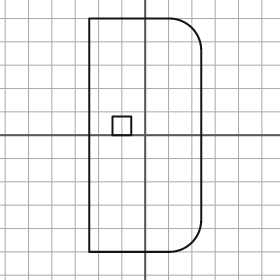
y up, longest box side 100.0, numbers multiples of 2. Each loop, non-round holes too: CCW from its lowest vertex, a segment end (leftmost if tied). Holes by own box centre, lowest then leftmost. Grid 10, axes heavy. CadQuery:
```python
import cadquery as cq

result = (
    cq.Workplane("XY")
    .moveTo(-24.0, -50.0)
    .lineTo(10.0, -50.0)
    .threePointArc((20.0, -46.0), (24.0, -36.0))
    .lineTo(24.0, 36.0)
    .threePointArc((20.0, 46.0), (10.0, 50.0))
    .lineTo(-24.0, 50.0)
    .close()
    .moveTo(-14.0, 0.0)
    .lineTo(-6.0, 0.0)
    .lineTo(-6.0, 8.0)
    .lineTo(-14.0, 8.0)
    .close()
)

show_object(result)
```